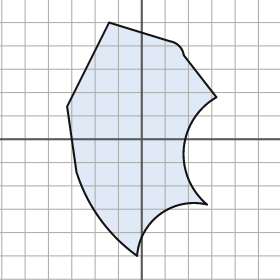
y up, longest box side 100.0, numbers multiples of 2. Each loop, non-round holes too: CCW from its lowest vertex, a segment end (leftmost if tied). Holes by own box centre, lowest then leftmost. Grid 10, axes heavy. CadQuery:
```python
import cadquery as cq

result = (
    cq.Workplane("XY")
    .moveTo(-2.0, -50.0)
    .threePointArc((8.0, -32.0), (28.0, -28.0))
    .threePointArc((18.0, -4.0), (32.0, 18.0))
    .lineTo(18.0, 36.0)
    .threePointArc((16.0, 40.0), (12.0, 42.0))
    .lineTo(-14.0, 50.0)
    .lineTo(-32.0, 14.0)
    .lineTo(-28.0, -14.0)
    .threePointArc((-18.0, -34.0), (-2.0, -50.0))
    .close()
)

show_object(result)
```